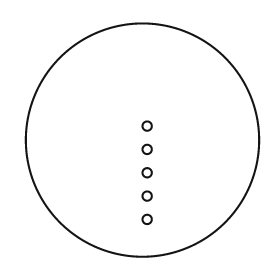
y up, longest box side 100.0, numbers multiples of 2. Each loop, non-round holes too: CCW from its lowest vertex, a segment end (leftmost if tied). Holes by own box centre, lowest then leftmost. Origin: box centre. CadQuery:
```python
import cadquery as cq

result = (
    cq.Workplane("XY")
    .moveTo(0.0, 0.0)
    .circle(50.0)
    .moveTo(2.0, -34.0)
    .circle(2.0)
    .moveTo(2.0, -24.0)
    .circle(2.0)
    .moveTo(2.0, -14.0)
    .circle(2.0)
    .moveTo(2.0, -4.0)
    .circle(2.0)
    .moveTo(2.0, 6.0)
    .circle(2.0)
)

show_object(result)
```